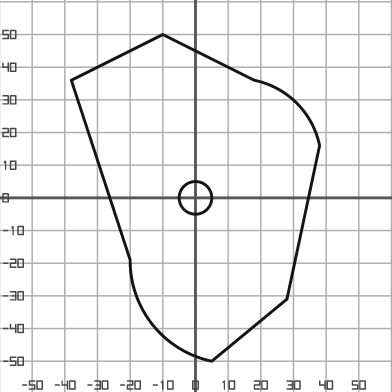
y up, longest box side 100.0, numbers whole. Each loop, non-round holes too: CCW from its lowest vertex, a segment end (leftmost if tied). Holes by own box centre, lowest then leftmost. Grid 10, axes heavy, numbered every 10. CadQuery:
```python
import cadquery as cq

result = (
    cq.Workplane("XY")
    .moveTo(5.0, -50.0)
    .lineTo(28.0, -31.0)
    .lineTo(38.0, 16.0)
    .threePointArc((31.0, 29.0), (18.0, 36.0))
    .lineTo(-10.0, 50.0)
    .lineTo(-38.0, 36.0)
    .lineTo(-20.0, -19.0)
    .threePointArc((-13.0, -39.0), (5.0, -50.0))
    .close()
    .moveTo(0.0, 0.0)
    .circle(5.0)
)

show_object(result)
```